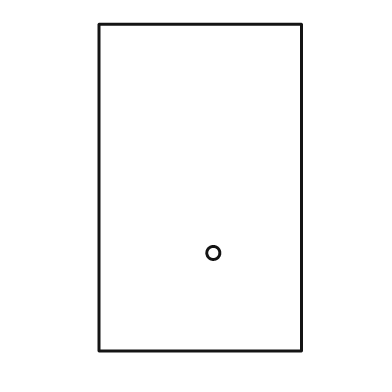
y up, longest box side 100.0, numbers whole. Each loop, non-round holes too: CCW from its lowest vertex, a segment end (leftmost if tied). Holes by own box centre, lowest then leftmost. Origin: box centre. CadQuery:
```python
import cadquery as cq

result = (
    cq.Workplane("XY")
    .moveTo(-31.0, -50.0)
    .lineTo(31.0, -50.0)
    .lineTo(31.0, 50.0)
    .lineTo(-31.0, 50.0)
    .close()
    .moveTo(4.0, -20.0)
    .circle(2.0)
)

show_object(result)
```